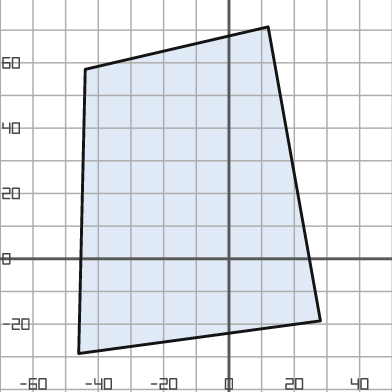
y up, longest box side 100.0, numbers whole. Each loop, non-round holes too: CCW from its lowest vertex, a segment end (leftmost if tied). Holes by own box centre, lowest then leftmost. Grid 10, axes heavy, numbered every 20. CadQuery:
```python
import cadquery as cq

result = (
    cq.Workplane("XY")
    .moveTo(-46.0, -29.0)
    .lineTo(28.0, -19.0)
    .lineTo(12.0, 71.0)
    .lineTo(-44.0, 58.0)
    .close()
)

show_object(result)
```